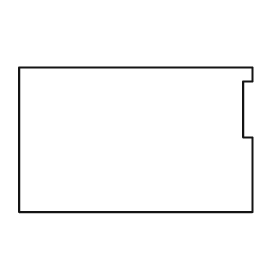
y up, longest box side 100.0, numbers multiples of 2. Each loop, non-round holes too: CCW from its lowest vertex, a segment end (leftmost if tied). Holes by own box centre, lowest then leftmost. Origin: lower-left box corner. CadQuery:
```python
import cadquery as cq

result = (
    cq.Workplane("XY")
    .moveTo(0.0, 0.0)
    .lineTo(100.0, 0.0)
    .lineTo(100.0, 32.0)
    .lineTo(96.0, 32.0)
    .lineTo(96.0, 56.0)
    .lineTo(100.0, 56.0)
    .lineTo(100.0, 62.0)
    .lineTo(0.0, 62.0)
    .close()
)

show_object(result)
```